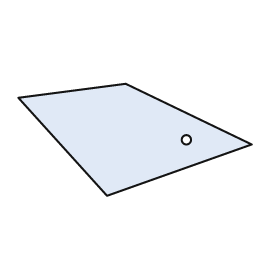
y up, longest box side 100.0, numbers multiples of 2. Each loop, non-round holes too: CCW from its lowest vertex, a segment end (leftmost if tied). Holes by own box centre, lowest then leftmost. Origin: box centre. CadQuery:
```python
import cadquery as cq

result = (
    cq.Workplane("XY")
    .moveTo(-12.0, -24.0)
    .lineTo(50.0, -2.0)
    .lineTo(-4.0, 24.0)
    .lineTo(-50.0, 18.0)
    .close()
    .moveTo(22.0, 0.0)
    .circle(2.0)
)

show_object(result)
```